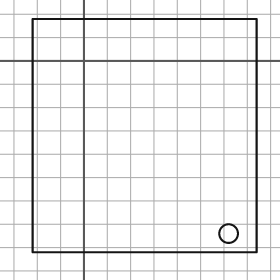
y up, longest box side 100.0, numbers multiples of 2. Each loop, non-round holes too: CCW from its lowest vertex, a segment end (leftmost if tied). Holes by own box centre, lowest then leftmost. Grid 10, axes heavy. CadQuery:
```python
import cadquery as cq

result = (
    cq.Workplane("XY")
    .moveTo(-22.0, -82.0)
    .lineTo(74.0, -82.0)
    .lineTo(74.0, 18.0)
    .lineTo(-22.0, 18.0)
    .close()
    .moveTo(62.0, -74.0)
    .circle(4.0)
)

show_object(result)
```